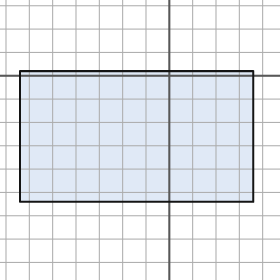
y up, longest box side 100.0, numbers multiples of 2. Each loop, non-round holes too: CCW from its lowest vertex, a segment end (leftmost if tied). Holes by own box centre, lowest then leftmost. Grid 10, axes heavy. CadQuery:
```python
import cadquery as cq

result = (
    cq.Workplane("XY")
    .moveTo(-64.0, -54.0)
    .lineTo(36.0, -54.0)
    .lineTo(36.0, 2.0)
    .lineTo(-64.0, 2.0)
    .close()
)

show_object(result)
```